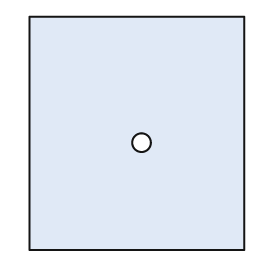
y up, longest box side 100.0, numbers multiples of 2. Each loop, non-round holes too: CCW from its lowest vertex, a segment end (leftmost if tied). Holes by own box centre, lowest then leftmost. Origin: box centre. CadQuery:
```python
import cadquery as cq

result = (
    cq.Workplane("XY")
    .moveTo(-46.0, -50.0)
    .lineTo(46.0, -50.0)
    .lineTo(46.0, 50.0)
    .lineTo(-46.0, 50.0)
    .close()
    .moveTo(2.0, -4.0)
    .circle(4.0)
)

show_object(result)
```